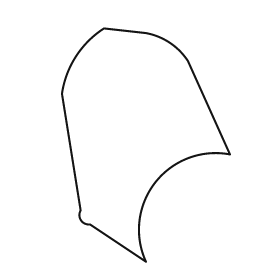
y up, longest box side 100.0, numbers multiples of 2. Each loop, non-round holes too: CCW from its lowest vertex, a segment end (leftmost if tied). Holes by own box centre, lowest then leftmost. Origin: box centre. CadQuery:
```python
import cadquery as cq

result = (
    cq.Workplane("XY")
    .moveTo(0.0, -50.0)
    .threePointArc((4.0, -16.0), (36.0, -4.0))
    .lineTo(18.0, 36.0)
    .threePointArc((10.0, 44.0), (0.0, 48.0))
    .lineTo(-18.0, 50.0)
    .threePointArc((-30.0, 38.0), (-36.0, 22.0))
    .lineTo(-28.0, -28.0)
    .threePointArc((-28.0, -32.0), (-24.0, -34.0))
    .close()
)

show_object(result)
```